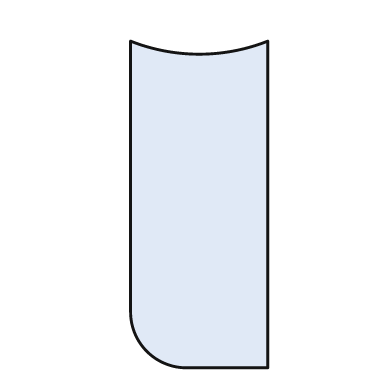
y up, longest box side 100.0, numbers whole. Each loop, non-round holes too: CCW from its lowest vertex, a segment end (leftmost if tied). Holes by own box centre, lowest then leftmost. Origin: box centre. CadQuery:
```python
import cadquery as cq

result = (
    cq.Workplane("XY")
    .moveTo(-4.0, -50.0)
    .lineTo(21.0, -50.0)
    .lineTo(21.0, 50.0)
    .threePointArc((0.0, 46.0), (-21.0, 50.0))
    .lineTo(-21.0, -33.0)
    .threePointArc((-16.0, -45.0), (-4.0, -50.0))
    .close()
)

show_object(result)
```